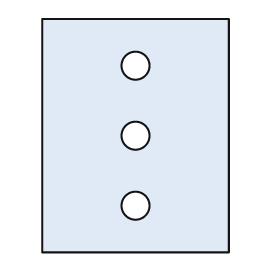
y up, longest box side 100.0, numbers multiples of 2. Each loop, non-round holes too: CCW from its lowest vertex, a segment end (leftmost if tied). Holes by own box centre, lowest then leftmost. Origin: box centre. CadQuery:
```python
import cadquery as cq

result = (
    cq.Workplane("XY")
    .moveTo(-40.0, -50.0)
    .lineTo(40.0, -50.0)
    .lineTo(40.0, 50.0)
    .lineTo(-40.0, 50.0)
    .close()
    .moveTo(0.0, -30.0)
    .circle(6.0)
    .moveTo(0.0, 0.0)
    .circle(6.0)
    .moveTo(0.0, 30.0)
    .circle(6.0)
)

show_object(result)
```